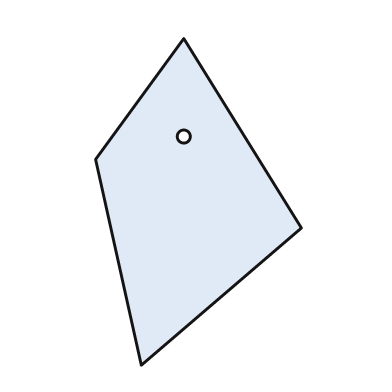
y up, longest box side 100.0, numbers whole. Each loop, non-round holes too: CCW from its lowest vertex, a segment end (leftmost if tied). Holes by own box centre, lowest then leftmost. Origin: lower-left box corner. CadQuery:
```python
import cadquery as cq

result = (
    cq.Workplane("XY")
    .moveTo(14.0, 0.0)
    .lineTo(63.0, 42.0)
    .lineTo(27.0, 100.0)
    .lineTo(0.0, 63.0)
    .close()
    .moveTo(27.0, 70.0)
    .circle(2.0)
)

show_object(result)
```